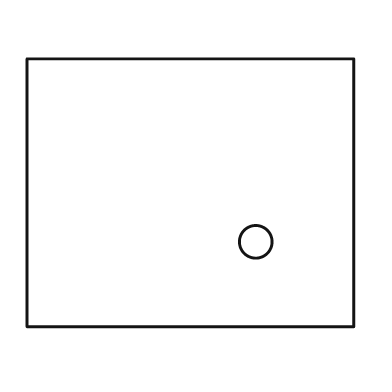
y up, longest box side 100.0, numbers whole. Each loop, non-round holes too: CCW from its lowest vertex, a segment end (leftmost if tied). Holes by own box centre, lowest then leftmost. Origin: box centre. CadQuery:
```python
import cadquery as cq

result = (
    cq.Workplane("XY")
    .moveTo(-50.0, -41.0)
    .lineTo(50.0, -41.0)
    .lineTo(50.0, 41.0)
    .lineTo(-50.0, 41.0)
    .close()
    .moveTo(20.0, -15.0)
    .circle(5.0)
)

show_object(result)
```